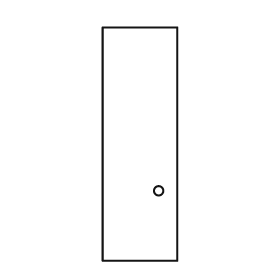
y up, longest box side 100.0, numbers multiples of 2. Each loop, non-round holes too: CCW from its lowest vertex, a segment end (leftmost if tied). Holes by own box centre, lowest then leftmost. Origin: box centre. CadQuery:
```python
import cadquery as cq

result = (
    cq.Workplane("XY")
    .moveTo(-16.0, -50.0)
    .lineTo(16.0, -50.0)
    .lineTo(16.0, 50.0)
    .lineTo(-16.0, 50.0)
    .close()
    .moveTo(8.0, -20.0)
    .circle(2.0)
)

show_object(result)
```